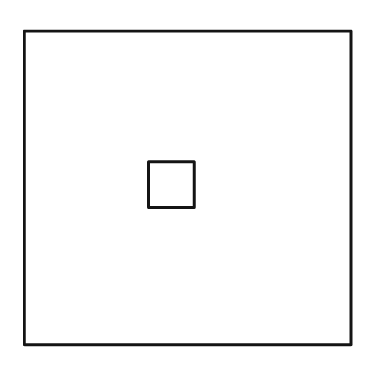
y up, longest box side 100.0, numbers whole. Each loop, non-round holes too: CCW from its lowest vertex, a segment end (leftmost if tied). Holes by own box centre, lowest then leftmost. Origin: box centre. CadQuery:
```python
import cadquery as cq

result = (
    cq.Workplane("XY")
    .moveTo(-50.0, -48.0)
    .lineTo(50.0, -48.0)
    .lineTo(50.0, 48.0)
    .lineTo(-50.0, 48.0)
    .close()
    .moveTo(-12.0, -6.0)
    .lineTo(2.0, -6.0)
    .lineTo(2.0, 8.0)
    .lineTo(-12.0, 8.0)
    .close()
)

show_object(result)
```